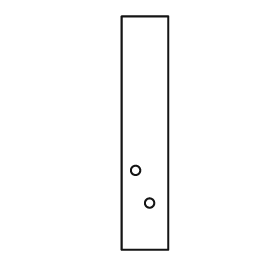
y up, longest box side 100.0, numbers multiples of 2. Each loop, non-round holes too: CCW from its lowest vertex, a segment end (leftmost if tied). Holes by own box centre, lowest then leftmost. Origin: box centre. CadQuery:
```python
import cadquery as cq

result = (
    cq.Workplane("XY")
    .moveTo(-10.0, -50.0)
    .lineTo(10.0, -50.0)
    .lineTo(10.0, 50.0)
    .lineTo(-10.0, 50.0)
    .close()
    .moveTo(2.0, -30.0)
    .circle(2.0)
    .moveTo(-4.0, -16.0)
    .circle(2.0)
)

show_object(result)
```